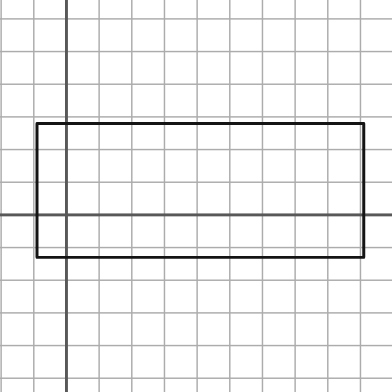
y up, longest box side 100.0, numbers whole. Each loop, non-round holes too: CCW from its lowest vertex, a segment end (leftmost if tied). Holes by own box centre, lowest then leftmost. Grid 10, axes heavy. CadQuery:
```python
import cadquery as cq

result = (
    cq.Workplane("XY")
    .moveTo(-9.0, -13.0)
    .lineTo(91.0, -13.0)
    .lineTo(91.0, 28.0)
    .lineTo(-9.0, 28.0)
    .close()
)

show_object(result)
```